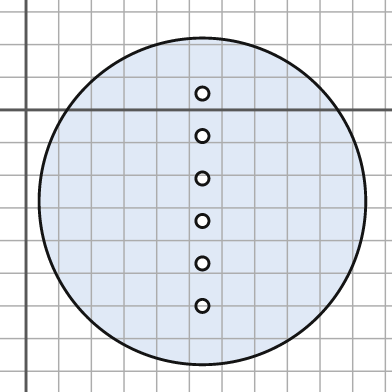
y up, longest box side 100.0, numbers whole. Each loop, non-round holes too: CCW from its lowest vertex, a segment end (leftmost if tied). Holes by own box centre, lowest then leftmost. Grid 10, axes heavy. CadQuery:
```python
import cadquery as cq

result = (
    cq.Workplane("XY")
    .moveTo(54.0, -28.0)
    .circle(50.0)
    .moveTo(54.0, -60.0)
    .circle(2.0)
    .moveTo(54.0, -47.0)
    .circle(2.0)
    .moveTo(54.0, -34.0)
    .circle(2.0)
    .moveTo(54.0, -21.0)
    .circle(2.0)
    .moveTo(54.0, -8.0)
    .circle(2.0)
    .moveTo(54.0, 5.0)
    .circle(2.0)
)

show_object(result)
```